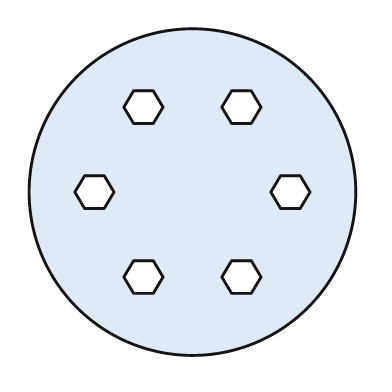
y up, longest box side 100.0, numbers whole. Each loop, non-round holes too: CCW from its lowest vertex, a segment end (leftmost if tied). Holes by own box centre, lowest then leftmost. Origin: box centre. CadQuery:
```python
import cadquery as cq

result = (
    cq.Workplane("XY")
    .moveTo(0.0, 0.0)
    .circle(50.0)
    .moveTo(-18.0, -31.0)
    .lineTo(-12.0, -31.0)
    .lineTo(-9.0, -26.0)
    .lineTo(-12.0, -21.0)
    .lineTo(-18.0, -21.0)
    .lineTo(-21.0, -26.0)
    .close()
    .moveTo(12.0, -31.0)
    .lineTo(18.0, -31.0)
    .lineTo(21.0, -26.0)
    .lineTo(18.0, -21.0)
    .lineTo(12.0, -21.0)
    .lineTo(9.0, -26.0)
    .close()
    .moveTo(-33.0, -5.0)
    .lineTo(-27.0, -5.0)
    .lineTo(-24.0, 0.0)
    .lineTo(-27.0, 5.0)
    .lineTo(-33.0, 5.0)
    .lineTo(-36.0, 0.0)
    .close()
    .moveTo(27.0, -5.0)
    .lineTo(33.0, -5.0)
    .lineTo(36.0, 0.0)
    .lineTo(33.0, 5.0)
    .lineTo(27.0, 5.0)
    .lineTo(24.0, 0.0)
    .close()
    .moveTo(-18.0, 21.0)
    .lineTo(-12.0, 21.0)
    .lineTo(-9.0, 26.0)
    .lineTo(-12.0, 31.0)
    .lineTo(-18.0, 31.0)
    .lineTo(-21.0, 26.0)
    .close()
    .moveTo(12.0, 21.0)
    .lineTo(18.0, 21.0)
    .lineTo(21.0, 26.0)
    .lineTo(18.0, 31.0)
    .lineTo(12.0, 31.0)
    .lineTo(9.0, 26.0)
    .close()
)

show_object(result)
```